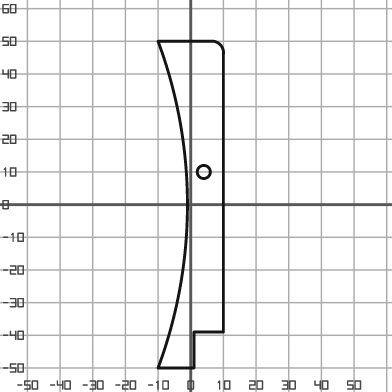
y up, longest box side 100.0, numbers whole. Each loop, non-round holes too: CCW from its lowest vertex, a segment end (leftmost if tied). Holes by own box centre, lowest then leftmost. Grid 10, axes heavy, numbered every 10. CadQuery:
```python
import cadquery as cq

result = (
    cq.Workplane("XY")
    .moveTo(-10.0, -50.0)
    .lineTo(1.0, -50.0)
    .lineTo(1.0, -39.0)
    .lineTo(10.0, -39.0)
    .lineTo(10.0, 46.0)
    .threePointArc((9.0, 49.0), (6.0, 50.0))
    .lineTo(-10.0, 50.0)
    .threePointArc((-1.0, 0.0), (-10.0, -50.0))
    .close()
    .moveTo(4.0, 10.0)
    .circle(2.0)
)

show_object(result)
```